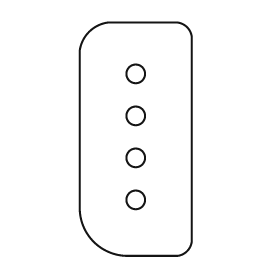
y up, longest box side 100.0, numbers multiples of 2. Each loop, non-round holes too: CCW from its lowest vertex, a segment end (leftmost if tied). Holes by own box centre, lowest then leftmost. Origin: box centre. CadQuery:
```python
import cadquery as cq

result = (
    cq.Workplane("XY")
    .moveTo(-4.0, -50.0)
    .lineTo(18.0, -50.0)
    .threePointArc((22.0, -48.0), (24.0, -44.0))
    .lineTo(24.0, 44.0)
    .threePointArc((22.0, 48.0), (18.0, 50.0))
    .lineTo(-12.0, 50.0)
    .threePointArc((-20.0, 46.0), (-24.0, 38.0))
    .lineTo(-24.0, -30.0)
    .threePointArc((-18.0, -44.0), (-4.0, -50.0))
    .close()
    .moveTo(0.0, -26.0)
    .circle(4.0)
    .moveTo(0.0, -8.0)
    .circle(4.0)
    .moveTo(0.0, 10.0)
    .circle(4.0)
    .moveTo(0.0, 28.0)
    .circle(4.0)
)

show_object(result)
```